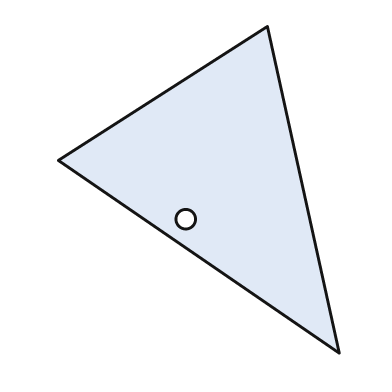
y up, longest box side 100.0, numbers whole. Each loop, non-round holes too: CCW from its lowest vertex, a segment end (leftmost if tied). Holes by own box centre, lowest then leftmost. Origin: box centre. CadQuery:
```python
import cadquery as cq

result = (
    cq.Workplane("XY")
    .moveTo(43.0, -50.0)
    .lineTo(21.0, 50.0)
    .lineTo(-43.0, 9.0)
    .close()
    .moveTo(-4.0, -9.0)
    .circle(3.0)
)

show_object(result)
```